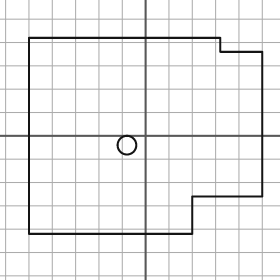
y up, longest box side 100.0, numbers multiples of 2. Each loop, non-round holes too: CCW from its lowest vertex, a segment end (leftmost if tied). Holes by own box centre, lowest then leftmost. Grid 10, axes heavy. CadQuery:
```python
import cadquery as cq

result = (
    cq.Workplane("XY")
    .moveTo(-50.0, -42.0)
    .lineTo(20.0, -42.0)
    .lineTo(20.0, -26.0)
    .lineTo(50.0, -26.0)
    .lineTo(50.0, 36.0)
    .lineTo(32.0, 36.0)
    .lineTo(32.0, 42.0)
    .lineTo(-50.0, 42.0)
    .close()
    .moveTo(-8.0, -4.0)
    .circle(4.0)
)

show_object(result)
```